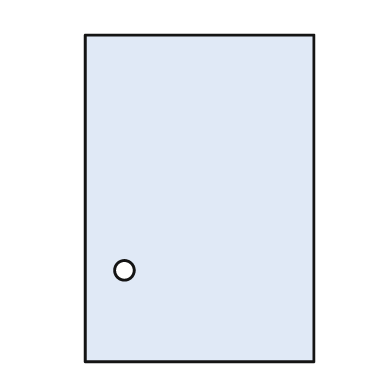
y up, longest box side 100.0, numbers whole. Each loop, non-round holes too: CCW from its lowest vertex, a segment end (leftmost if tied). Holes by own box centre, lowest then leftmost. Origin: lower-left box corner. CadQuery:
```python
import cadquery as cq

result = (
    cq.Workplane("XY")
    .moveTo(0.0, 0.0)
    .lineTo(70.0, 0.0)
    .lineTo(70.0, 100.0)
    .lineTo(0.0, 100.0)
    .close()
    .moveTo(12.0, 28.0)
    .circle(3.0)
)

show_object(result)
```